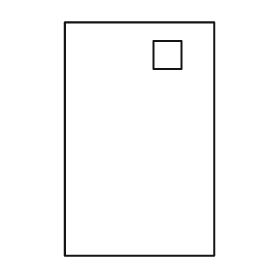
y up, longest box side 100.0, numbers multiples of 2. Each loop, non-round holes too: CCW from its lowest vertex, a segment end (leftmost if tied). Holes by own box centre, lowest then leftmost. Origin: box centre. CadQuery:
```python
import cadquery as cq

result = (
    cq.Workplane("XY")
    .moveTo(-32.0, -50.0)
    .lineTo(32.0, -50.0)
    .lineTo(32.0, 50.0)
    .lineTo(-32.0, 50.0)
    .close()
    .moveTo(6.0, 30.0)
    .lineTo(18.0, 30.0)
    .lineTo(18.0, 42.0)
    .lineTo(6.0, 42.0)
    .close()
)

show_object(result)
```